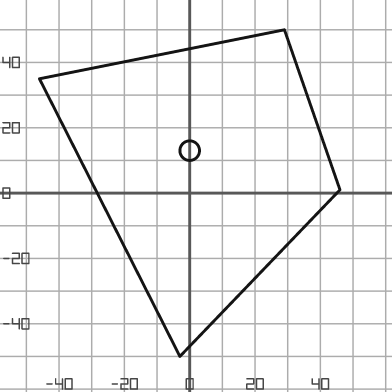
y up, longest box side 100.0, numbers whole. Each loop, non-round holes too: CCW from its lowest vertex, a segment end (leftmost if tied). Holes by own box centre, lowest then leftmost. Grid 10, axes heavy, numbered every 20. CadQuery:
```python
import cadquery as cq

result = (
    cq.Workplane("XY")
    .moveTo(-3.0, -50.0)
    .lineTo(46.0, 1.0)
    .lineTo(29.0, 50.0)
    .lineTo(-46.0, 35.0)
    .close()
    .moveTo(0.0, 13.0)
    .circle(3.0)
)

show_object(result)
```